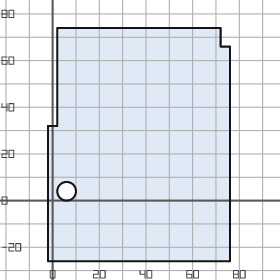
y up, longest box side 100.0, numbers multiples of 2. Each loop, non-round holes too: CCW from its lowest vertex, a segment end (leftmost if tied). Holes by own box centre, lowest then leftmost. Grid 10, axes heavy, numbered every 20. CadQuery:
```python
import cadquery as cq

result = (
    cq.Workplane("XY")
    .moveTo(-2.0, -26.0)
    .lineTo(76.0, -26.0)
    .lineTo(76.0, 66.0)
    .lineTo(72.0, 66.0)
    .lineTo(72.0, 74.0)
    .lineTo(2.0, 74.0)
    .lineTo(2.0, 32.0)
    .lineTo(-2.0, 32.0)
    .close()
    .moveTo(6.0, 4.0)
    .circle(4.0)
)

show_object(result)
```